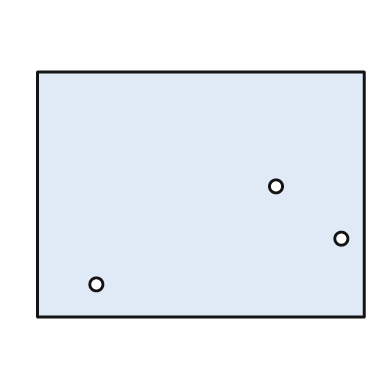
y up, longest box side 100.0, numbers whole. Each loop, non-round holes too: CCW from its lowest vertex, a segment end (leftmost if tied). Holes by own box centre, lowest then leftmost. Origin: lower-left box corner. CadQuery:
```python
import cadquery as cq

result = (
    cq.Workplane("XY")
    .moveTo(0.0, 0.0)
    .lineTo(100.0, 0.0)
    .lineTo(100.0, 75.0)
    .lineTo(0.0, 75.0)
    .close()
    .moveTo(18.0, 10.0)
    .circle(2.0)
    .moveTo(93.0, 24.0)
    .circle(2.0)
    .moveTo(73.0, 40.0)
    .circle(2.0)
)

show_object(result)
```